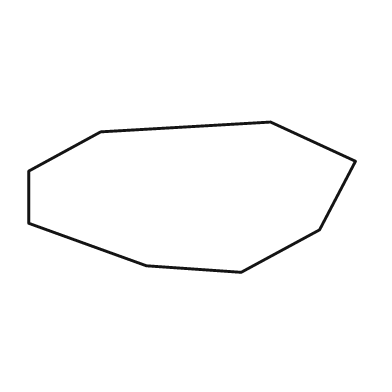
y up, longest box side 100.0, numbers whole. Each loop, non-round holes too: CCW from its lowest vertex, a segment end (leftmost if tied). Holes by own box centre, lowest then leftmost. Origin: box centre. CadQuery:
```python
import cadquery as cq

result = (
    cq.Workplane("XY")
    .moveTo(15.0, -23.0)
    .lineTo(39.0, -10.0)
    .lineTo(50.0, 11.0)
    .lineTo(24.0, 23.0)
    .lineTo(-28.0, 20.0)
    .lineTo(-50.0, 8.0)
    .lineTo(-50.0, -8.0)
    .lineTo(-14.0, -21.0)
    .close()
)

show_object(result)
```